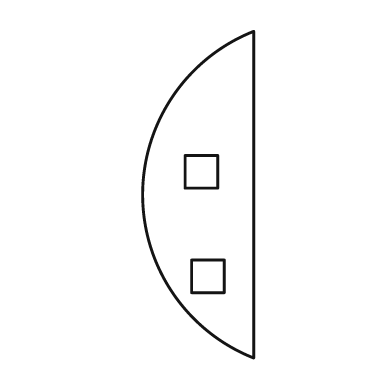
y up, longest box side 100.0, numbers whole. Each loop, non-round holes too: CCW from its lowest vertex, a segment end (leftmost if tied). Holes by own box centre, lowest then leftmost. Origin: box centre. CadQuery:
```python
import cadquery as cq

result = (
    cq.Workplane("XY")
    .moveTo(17.0, -50.0)
    .lineTo(17.0, 50.0)
    .threePointArc((-17.0, 0.0), (17.0, -50.0))
    .close()
    .moveTo(-2.0, -30.0)
    .lineTo(8.0, -30.0)
    .lineTo(8.0, -20.0)
    .lineTo(-2.0, -20.0)
    .close()
    .moveTo(-4.0, 2.0)
    .lineTo(6.0, 2.0)
    .lineTo(6.0, 12.0)
    .lineTo(-4.0, 12.0)
    .close()
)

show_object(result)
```